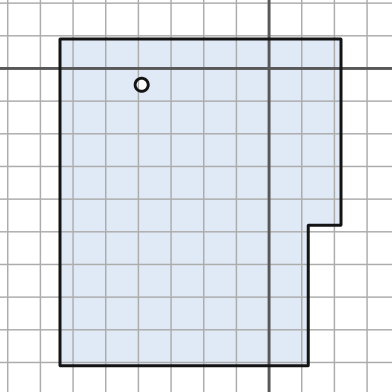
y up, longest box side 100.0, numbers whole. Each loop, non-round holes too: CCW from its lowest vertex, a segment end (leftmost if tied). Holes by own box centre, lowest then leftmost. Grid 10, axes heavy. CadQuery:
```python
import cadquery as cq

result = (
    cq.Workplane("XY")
    .moveTo(-64.0, -91.0)
    .lineTo(12.0, -91.0)
    .lineTo(12.0, -48.0)
    .lineTo(22.0, -48.0)
    .lineTo(22.0, 9.0)
    .lineTo(-64.0, 9.0)
    .close()
    .moveTo(-39.0, -5.0)
    .circle(2.0)
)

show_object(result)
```